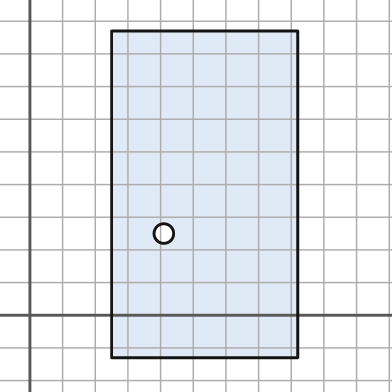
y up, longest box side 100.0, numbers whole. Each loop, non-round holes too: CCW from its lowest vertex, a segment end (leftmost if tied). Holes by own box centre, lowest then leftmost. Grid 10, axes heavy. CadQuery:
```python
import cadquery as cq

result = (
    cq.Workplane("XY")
    .moveTo(25.0, -13.0)
    .lineTo(82.0, -13.0)
    .lineTo(82.0, 87.0)
    .lineTo(25.0, 87.0)
    .close()
    .moveTo(41.0, 25.0)
    .circle(3.0)
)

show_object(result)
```